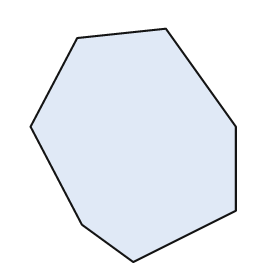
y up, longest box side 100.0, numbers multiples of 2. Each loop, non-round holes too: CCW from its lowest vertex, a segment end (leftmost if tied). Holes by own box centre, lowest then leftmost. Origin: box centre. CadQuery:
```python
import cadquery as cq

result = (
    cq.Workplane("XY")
    .moveTo(0.0, -50.0)
    .lineTo(44.0, -28.0)
    .lineTo(44.0, 8.0)
    .lineTo(14.0, 50.0)
    .lineTo(-24.0, 46.0)
    .lineTo(-44.0, 8.0)
    .lineTo(-22.0, -34.0)
    .close()
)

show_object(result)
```